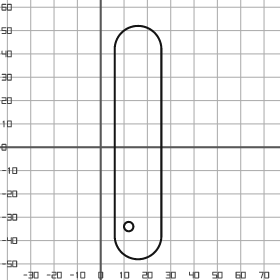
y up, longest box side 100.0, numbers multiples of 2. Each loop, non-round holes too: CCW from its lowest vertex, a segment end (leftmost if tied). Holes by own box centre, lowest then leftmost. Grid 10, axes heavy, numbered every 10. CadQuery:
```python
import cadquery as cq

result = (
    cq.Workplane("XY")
    .moveTo(6.0, -38.0)
    .threePointArc((16.0, -48.0), (26.0, -38.0))
    .lineTo(26.0, 42.0)
    .threePointArc((16.0, 52.0), (6.0, 42.0))
    .close()
    .moveTo(12.0, -34.0)
    .circle(2.0)
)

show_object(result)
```